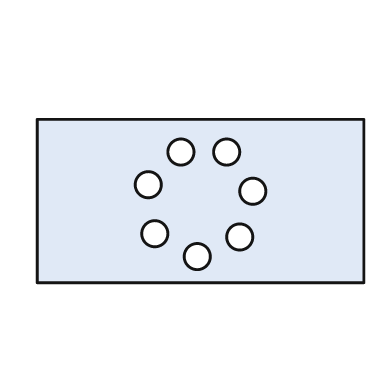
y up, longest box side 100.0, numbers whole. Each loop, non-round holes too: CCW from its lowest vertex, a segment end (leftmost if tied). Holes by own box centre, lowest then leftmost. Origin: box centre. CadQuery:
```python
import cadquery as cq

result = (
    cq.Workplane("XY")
    .moveTo(-50.0, -25.0)
    .lineTo(50.0, -25.0)
    .lineTo(50.0, 25.0)
    .lineTo(-50.0, 25.0)
    .close()
    .moveTo(-1.0, -17.0)
    .circle(4.0)
    .moveTo(12.0, -11.0)
    .circle(4.0)
    .moveTo(-14.0, -10.0)
    .circle(4.0)
    .moveTo(16.0, 3.0)
    .circle(4.0)
    .moveTo(-16.0, 5.0)
    .circle(4.0)
    .moveTo(-6.0, 15.0)
    .circle(4.0)
    .moveTo(8.0, 15.0)
    .circle(4.0)
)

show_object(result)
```